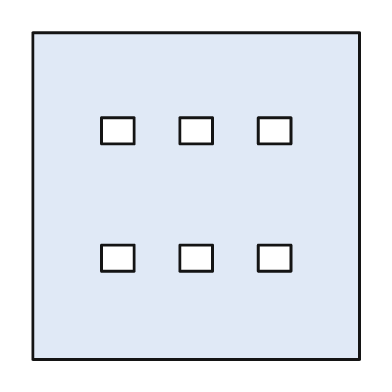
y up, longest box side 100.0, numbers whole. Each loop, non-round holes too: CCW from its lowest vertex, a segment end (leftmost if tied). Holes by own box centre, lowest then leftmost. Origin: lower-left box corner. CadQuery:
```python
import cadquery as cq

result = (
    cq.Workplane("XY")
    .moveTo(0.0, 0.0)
    .lineTo(100.0, 0.0)
    .lineTo(100.0, 100.0)
    .lineTo(0.0, 100.0)
    .close()
    .moveTo(21.0, 27.0)
    .lineTo(31.0, 27.0)
    .lineTo(31.0, 35.0)
    .lineTo(21.0, 35.0)
    .close()
    .moveTo(45.0, 27.0)
    .lineTo(55.0, 27.0)
    .lineTo(55.0, 35.0)
    .lineTo(45.0, 35.0)
    .close()
    .moveTo(69.0, 27.0)
    .lineTo(79.0, 27.0)
    .lineTo(79.0, 35.0)
    .lineTo(69.0, 35.0)
    .close()
    .moveTo(21.0, 66.0)
    .lineTo(31.0, 66.0)
    .lineTo(31.0, 74.0)
    .lineTo(21.0, 74.0)
    .close()
    .moveTo(45.0, 66.0)
    .lineTo(55.0, 66.0)
    .lineTo(55.0, 74.0)
    .lineTo(45.0, 74.0)
    .close()
    .moveTo(69.0, 66.0)
    .lineTo(79.0, 66.0)
    .lineTo(79.0, 74.0)
    .lineTo(69.0, 74.0)
    .close()
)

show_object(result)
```